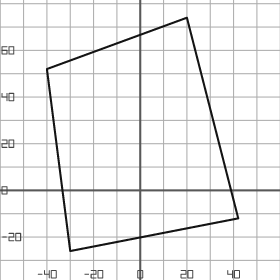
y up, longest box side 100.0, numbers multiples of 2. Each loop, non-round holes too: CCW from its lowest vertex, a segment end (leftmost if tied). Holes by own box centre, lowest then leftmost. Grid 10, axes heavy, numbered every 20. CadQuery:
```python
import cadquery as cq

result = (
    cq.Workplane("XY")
    .moveTo(-30.0, -26.0)
    .lineTo(42.0, -12.0)
    .lineTo(20.0, 74.0)
    .lineTo(-40.0, 52.0)
    .close()
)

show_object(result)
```